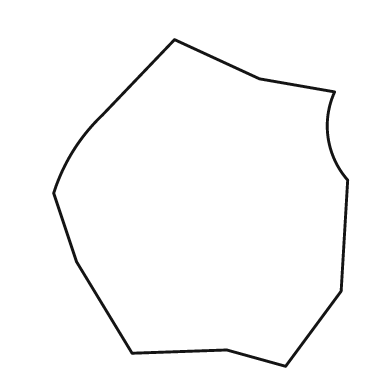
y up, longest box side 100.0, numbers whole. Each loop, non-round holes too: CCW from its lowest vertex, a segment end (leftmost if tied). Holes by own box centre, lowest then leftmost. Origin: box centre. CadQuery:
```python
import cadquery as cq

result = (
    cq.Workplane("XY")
    .moveTo(26.0, -50.0)
    .lineTo(43.0, -27.0)
    .lineTo(45.0, 7.0)
    .threePointArc((39.0, 20.0), (41.0, 34.0))
    .lineTo(18.0, 38.0)
    .lineTo(-8.0, 50.0)
    .lineTo(-30.0, 27.0)
    .threePointArc((-39.0, 16.0), (-45.0, 3.0))
    .lineTo(-38.0, -18.0)
    .lineTo(-21.0, -46.0)
    .lineTo(8.0, -45.0)
    .close()
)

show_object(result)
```